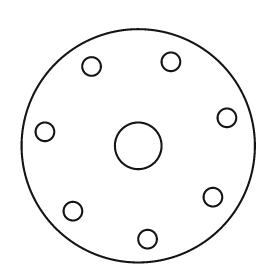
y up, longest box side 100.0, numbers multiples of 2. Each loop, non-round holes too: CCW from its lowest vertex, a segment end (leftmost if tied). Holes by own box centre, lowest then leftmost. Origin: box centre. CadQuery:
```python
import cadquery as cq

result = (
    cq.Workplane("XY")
    .moveTo(0.0, 0.0)
    .circle(50.0)
    .moveTo(4.0, -40.0)
    .circle(4.0)
    .moveTo(-28.0, -28.0)
    .circle(4.0)
    .moveTo(32.0, -22.0)
    .circle(4.0)
    .moveTo(0.0, 0.0)
    .circle(10.0)
    .moveTo(-40.0, 6.0)
    .circle(4.0)
    .moveTo(38.0, 12.0)
    .circle(4.0)
    .moveTo(-20.0, 34.0)
    .circle(4.0)
    .moveTo(14.0, 36.0)
    .circle(4.0)
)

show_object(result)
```